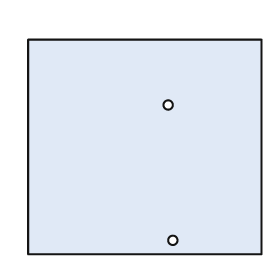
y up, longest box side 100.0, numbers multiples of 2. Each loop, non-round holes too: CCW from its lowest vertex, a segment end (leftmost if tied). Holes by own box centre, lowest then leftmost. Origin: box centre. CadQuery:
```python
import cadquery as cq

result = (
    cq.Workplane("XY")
    .moveTo(-50.0, -46.0)
    .lineTo(50.0, -46.0)
    .lineTo(50.0, 46.0)
    .lineTo(-50.0, 46.0)
    .close()
    .moveTo(12.0, -40.0)
    .circle(2.0)
    .moveTo(10.0, 18.0)
    .circle(2.0)
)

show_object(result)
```